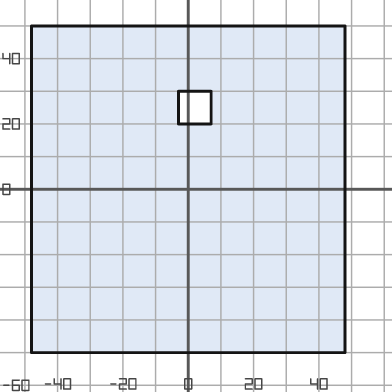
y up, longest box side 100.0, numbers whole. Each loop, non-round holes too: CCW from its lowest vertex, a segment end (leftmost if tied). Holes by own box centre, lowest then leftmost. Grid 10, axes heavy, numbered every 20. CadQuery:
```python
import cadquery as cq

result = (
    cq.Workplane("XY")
    .moveTo(-48.0, -50.0)
    .lineTo(48.0, -50.0)
    .lineTo(48.0, 50.0)
    .lineTo(-48.0, 50.0)
    .close()
    .moveTo(-3.0, 20.0)
    .lineTo(7.0, 20.0)
    .lineTo(7.0, 30.0)
    .lineTo(-3.0, 30.0)
    .close()
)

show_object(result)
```